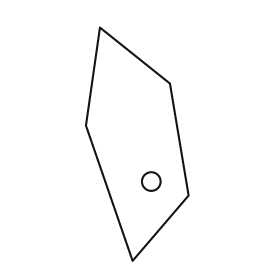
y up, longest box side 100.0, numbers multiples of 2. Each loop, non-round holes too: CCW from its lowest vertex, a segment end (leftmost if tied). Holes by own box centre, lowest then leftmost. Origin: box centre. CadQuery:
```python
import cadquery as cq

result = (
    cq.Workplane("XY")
    .moveTo(-2.0, -50.0)
    .lineTo(22.0, -22.0)
    .lineTo(14.0, 26.0)
    .lineTo(-16.0, 50.0)
    .lineTo(-22.0, 8.0)
    .close()
    .moveTo(6.0, -16.0)
    .circle(4.0)
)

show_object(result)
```